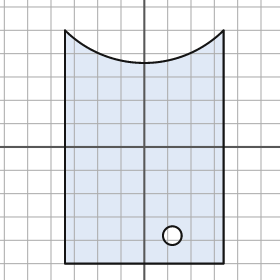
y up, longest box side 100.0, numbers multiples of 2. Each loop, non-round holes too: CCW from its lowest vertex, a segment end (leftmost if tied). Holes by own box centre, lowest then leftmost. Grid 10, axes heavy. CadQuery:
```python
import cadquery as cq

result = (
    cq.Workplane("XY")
    .moveTo(-34.0, -50.0)
    .lineTo(34.0, -50.0)
    .lineTo(34.0, 50.0)
    .threePointArc((0.0, 36.0), (-34.0, 50.0))
    .close()
    .moveTo(12.0, -38.0)
    .circle(4.0)
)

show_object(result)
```